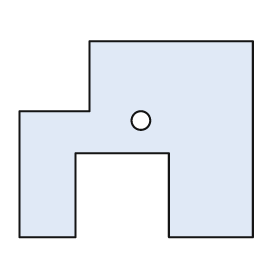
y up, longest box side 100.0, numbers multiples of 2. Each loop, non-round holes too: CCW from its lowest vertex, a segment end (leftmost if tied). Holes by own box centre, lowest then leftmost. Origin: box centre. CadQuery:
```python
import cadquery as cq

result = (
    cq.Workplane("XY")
    .moveTo(-50.0, -42.0)
    .lineTo(-26.0, -42.0)
    .lineTo(-26.0, -6.0)
    .lineTo(14.0, -6.0)
    .lineTo(14.0, -42.0)
    .lineTo(50.0, -42.0)
    .lineTo(50.0, 42.0)
    .lineTo(-20.0, 42.0)
    .lineTo(-20.0, 12.0)
    .lineTo(-50.0, 12.0)
    .close()
    .moveTo(2.0, 8.0)
    .circle(4.0)
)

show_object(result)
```